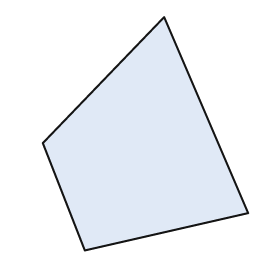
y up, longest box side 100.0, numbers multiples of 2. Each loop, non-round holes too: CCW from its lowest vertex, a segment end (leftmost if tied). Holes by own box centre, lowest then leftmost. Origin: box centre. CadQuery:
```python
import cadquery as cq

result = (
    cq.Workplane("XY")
    .moveTo(-26.0, -50.0)
    .lineTo(44.0, -34.0)
    .lineTo(8.0, 50.0)
    .lineTo(-44.0, -4.0)
    .close()
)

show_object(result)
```